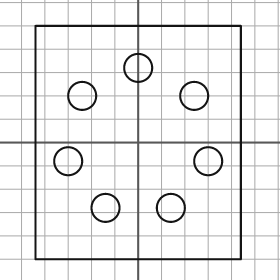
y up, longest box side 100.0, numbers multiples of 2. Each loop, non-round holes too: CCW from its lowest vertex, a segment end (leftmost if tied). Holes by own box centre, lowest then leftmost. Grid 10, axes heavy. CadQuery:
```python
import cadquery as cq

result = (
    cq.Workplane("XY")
    .moveTo(-44.0, -50.0)
    .lineTo(44.0, -50.0)
    .lineTo(44.0, 50.0)
    .lineTo(-44.0, 50.0)
    .close()
    .moveTo(-14.0, -28.0)
    .circle(6.0)
    .moveTo(14.0, -28.0)
    .circle(6.0)
    .moveTo(-30.0, -8.0)
    .circle(6.0)
    .moveTo(30.0, -8.0)
    .circle(6.0)
    .moveTo(-24.0, 20.0)
    .circle(6.0)
    .moveTo(24.0, 20.0)
    .circle(6.0)
    .moveTo(0.0, 32.0)
    .circle(6.0)
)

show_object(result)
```